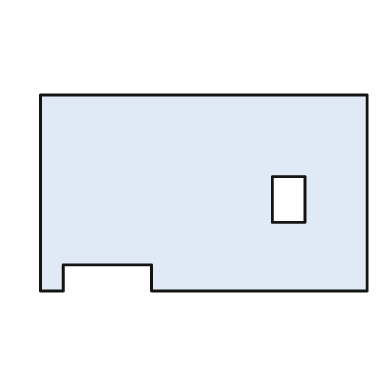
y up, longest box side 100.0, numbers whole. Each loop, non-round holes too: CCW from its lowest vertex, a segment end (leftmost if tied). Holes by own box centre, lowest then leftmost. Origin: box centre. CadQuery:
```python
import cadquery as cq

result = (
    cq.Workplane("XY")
    .moveTo(-50.0, -30.0)
    .lineTo(-43.0, -30.0)
    .lineTo(-43.0, -22.0)
    .lineTo(-16.0, -22.0)
    .lineTo(-16.0, -30.0)
    .lineTo(50.0, -30.0)
    .lineTo(50.0, 30.0)
    .lineTo(-50.0, 30.0)
    .close()
    .moveTo(21.0, -9.0)
    .lineTo(31.0, -9.0)
    .lineTo(31.0, 5.0)
    .lineTo(21.0, 5.0)
    .close()
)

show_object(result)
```